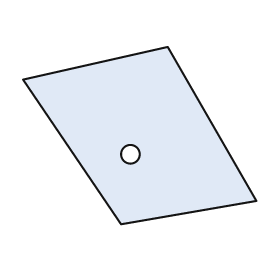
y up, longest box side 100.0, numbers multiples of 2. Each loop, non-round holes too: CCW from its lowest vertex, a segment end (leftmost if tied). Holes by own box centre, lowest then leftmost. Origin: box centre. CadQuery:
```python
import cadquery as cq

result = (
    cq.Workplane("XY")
    .moveTo(-8.0, -38.0)
    .lineTo(50.0, -28.0)
    .lineTo(12.0, 38.0)
    .lineTo(-50.0, 24.0)
    .close()
    .moveTo(-4.0, -8.0)
    .circle(4.0)
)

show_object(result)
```